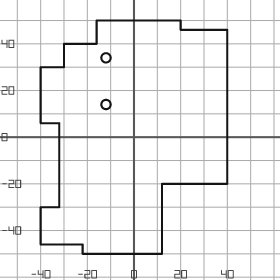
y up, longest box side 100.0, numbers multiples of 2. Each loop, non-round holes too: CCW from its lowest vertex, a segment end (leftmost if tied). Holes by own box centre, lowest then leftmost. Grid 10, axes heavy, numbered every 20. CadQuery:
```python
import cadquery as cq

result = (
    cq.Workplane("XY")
    .moveTo(-22.0, -50.0)
    .lineTo(12.0, -50.0)
    .lineTo(12.0, -20.0)
    .lineTo(40.0, -20.0)
    .lineTo(40.0, 46.0)
    .lineTo(20.0, 46.0)
    .lineTo(20.0, 50.0)
    .lineTo(-16.0, 50.0)
    .lineTo(-16.0, 40.0)
    .lineTo(-30.0, 40.0)
    .lineTo(-30.0, 30.0)
    .lineTo(-40.0, 30.0)
    .lineTo(-40.0, 6.0)
    .lineTo(-32.0, 6.0)
    .lineTo(-32.0, -30.0)
    .lineTo(-40.0, -30.0)
    .lineTo(-40.0, -46.0)
    .lineTo(-22.0, -46.0)
    .close()
    .moveTo(-12.0, 14.0)
    .circle(2.0)
    .moveTo(-12.0, 34.0)
    .circle(2.0)
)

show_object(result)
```